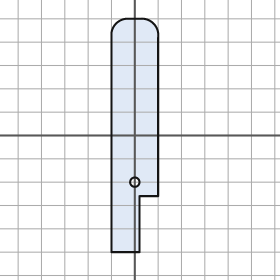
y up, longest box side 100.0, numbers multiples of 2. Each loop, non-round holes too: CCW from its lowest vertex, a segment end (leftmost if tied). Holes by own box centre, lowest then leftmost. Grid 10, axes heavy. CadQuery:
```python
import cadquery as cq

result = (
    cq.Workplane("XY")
    .moveTo(-10.0, -50.0)
    .lineTo(2.0, -50.0)
    .lineTo(2.0, -26.0)
    .lineTo(10.0, -26.0)
    .lineTo(10.0, 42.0)
    .threePointArc((8.0, 48.0), (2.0, 50.0))
    .lineTo(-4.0, 50.0)
    .threePointArc((-8.0, 48.0), (-10.0, 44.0))
    .close()
    .moveTo(0.0, -20.0)
    .circle(2.0)
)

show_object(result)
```